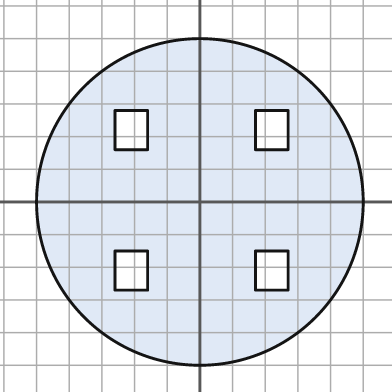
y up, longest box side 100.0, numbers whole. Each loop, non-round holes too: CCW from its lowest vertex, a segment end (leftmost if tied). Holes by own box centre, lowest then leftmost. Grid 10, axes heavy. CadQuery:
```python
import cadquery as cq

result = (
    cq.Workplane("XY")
    .moveTo(0.0, 0.0)
    .circle(50.0)
    .moveTo(-26.0, -27.0)
    .lineTo(-16.0, -27.0)
    .lineTo(-16.0, -15.0)
    .lineTo(-26.0, -15.0)
    .close()
    .moveTo(17.0, -27.0)
    .lineTo(27.0, -27.0)
    .lineTo(27.0, -15.0)
    .lineTo(17.0, -15.0)
    .close()
    .moveTo(-26.0, 16.0)
    .lineTo(-16.0, 16.0)
    .lineTo(-16.0, 28.0)
    .lineTo(-26.0, 28.0)
    .close()
    .moveTo(17.0, 16.0)
    .lineTo(27.0, 16.0)
    .lineTo(27.0, 28.0)
    .lineTo(17.0, 28.0)
    .close()
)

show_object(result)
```